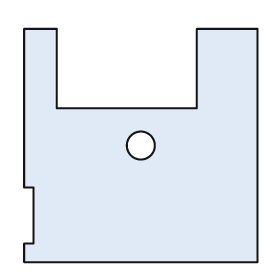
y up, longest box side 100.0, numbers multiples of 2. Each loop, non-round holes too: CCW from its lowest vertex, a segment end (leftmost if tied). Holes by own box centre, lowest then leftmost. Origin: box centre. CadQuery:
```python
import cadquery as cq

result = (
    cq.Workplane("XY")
    .moveTo(-50.0, -50.0)
    .lineTo(50.0, -50.0)
    .lineTo(50.0, 50.0)
    .lineTo(24.0, 50.0)
    .lineTo(24.0, 16.0)
    .lineTo(-36.0, 16.0)
    .lineTo(-36.0, 50.0)
    .lineTo(-50.0, 50.0)
    .lineTo(-50.0, -18.0)
    .lineTo(-46.0, -18.0)
    .lineTo(-46.0, -42.0)
    .lineTo(-50.0, -42.0)
    .close()
    .moveTo(0.0, 0.0)
    .circle(6.0)
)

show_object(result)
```